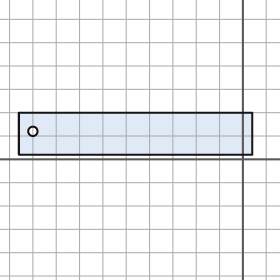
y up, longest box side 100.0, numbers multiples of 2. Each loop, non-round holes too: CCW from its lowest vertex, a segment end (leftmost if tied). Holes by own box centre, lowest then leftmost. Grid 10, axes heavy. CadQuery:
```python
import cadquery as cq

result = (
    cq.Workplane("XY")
    .moveTo(-96.0, 2.0)
    .lineTo(4.0, 2.0)
    .lineTo(4.0, 20.0)
    .lineTo(-96.0, 20.0)
    .close()
    .moveTo(-90.0, 12.0)
    .circle(2.0)
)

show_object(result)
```